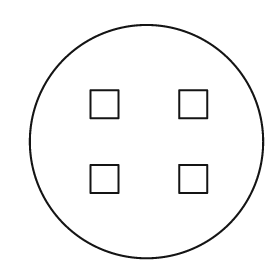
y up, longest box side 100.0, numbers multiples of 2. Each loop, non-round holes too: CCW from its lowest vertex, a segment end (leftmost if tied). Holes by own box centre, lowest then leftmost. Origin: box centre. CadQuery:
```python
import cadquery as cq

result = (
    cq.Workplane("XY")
    .moveTo(0.0, 0.0)
    .circle(50.0)
    .moveTo(-24.0, -22.0)
    .lineTo(-12.0, -22.0)
    .lineTo(-12.0, -10.0)
    .lineTo(-24.0, -10.0)
    .close()
    .moveTo(14.0, -22.0)
    .lineTo(26.0, -22.0)
    .lineTo(26.0, -10.0)
    .lineTo(14.0, -10.0)
    .close()
    .moveTo(-24.0, 10.0)
    .lineTo(-12.0, 10.0)
    .lineTo(-12.0, 22.0)
    .lineTo(-24.0, 22.0)
    .close()
    .moveTo(14.0, 10.0)
    .lineTo(26.0, 10.0)
    .lineTo(26.0, 22.0)
    .lineTo(14.0, 22.0)
    .close()
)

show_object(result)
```